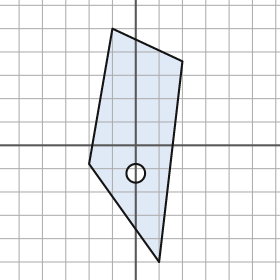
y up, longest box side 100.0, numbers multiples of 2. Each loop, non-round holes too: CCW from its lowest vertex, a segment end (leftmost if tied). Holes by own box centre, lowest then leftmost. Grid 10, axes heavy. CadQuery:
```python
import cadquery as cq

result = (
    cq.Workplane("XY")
    .moveTo(10.0, -50.0)
    .lineTo(20.0, 36.0)
    .lineTo(-10.0, 50.0)
    .lineTo(-20.0, -8.0)
    .close()
    .moveTo(0.0, -12.0)
    .circle(4.0)
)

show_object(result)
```